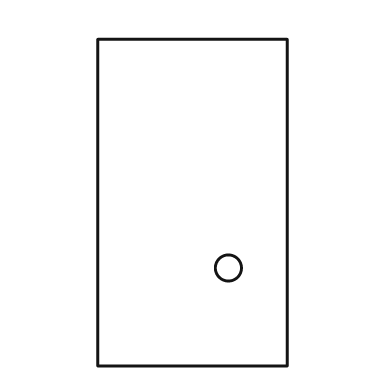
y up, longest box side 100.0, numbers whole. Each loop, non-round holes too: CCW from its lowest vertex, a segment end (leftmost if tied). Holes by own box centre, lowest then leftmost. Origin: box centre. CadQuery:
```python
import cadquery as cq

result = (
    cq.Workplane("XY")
    .moveTo(-29.0, -50.0)
    .lineTo(29.0, -50.0)
    .lineTo(29.0, 50.0)
    .lineTo(-29.0, 50.0)
    .close()
    .moveTo(11.0, -20.0)
    .circle(4.0)
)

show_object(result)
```